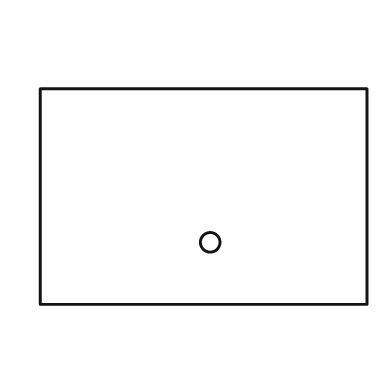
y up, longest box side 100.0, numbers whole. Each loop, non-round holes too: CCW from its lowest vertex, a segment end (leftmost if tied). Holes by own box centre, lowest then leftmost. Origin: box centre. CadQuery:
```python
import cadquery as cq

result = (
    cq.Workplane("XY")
    .moveTo(-50.0, -33.0)
    .lineTo(50.0, -33.0)
    .lineTo(50.0, 33.0)
    .lineTo(-50.0, 33.0)
    .close()
    .moveTo(2.0, -14.0)
    .circle(3.0)
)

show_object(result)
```